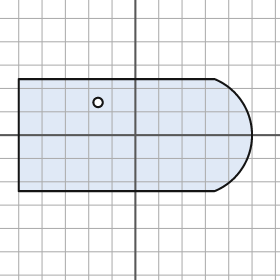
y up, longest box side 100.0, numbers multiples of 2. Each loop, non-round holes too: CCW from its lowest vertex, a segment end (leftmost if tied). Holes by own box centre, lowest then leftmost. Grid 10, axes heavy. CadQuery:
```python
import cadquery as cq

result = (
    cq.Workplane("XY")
    .moveTo(-50.0, -24.0)
    .lineTo(34.0, -24.0)
    .threePointArc((50.0, 0.0), (34.0, 24.0))
    .lineTo(-50.0, 24.0)
    .close()
    .moveTo(-16.0, 14.0)
    .circle(2.0)
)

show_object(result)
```